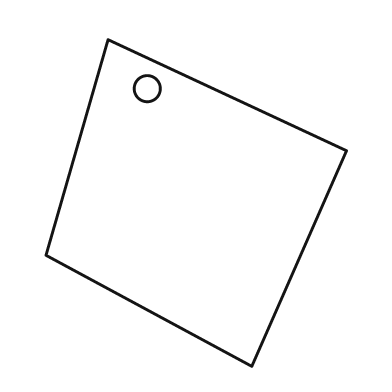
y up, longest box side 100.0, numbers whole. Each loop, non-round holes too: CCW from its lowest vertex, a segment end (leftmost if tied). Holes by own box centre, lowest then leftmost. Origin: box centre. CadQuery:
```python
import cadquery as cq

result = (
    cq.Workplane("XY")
    .moveTo(17.0, -50.0)
    .lineTo(46.0, 16.0)
    .lineTo(-27.0, 50.0)
    .lineTo(-46.0, -16.0)
    .close()
    .moveTo(-15.0, 35.0)
    .circle(4.0)
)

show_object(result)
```